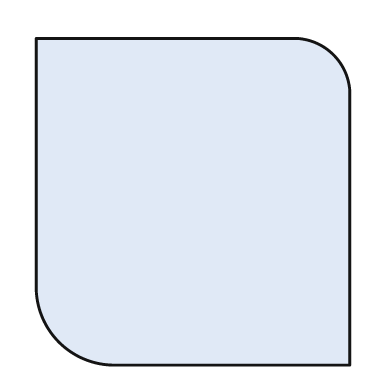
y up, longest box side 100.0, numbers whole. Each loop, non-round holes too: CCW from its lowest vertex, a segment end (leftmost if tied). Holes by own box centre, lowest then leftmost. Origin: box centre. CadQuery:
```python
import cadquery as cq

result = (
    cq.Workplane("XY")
    .moveTo(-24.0, -50.0)
    .lineTo(48.0, -50.0)
    .lineTo(48.0, 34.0)
    .threePointArc((43.0, 45.0), (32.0, 50.0))
    .lineTo(-48.0, 50.0)
    .lineTo(-48.0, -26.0)
    .threePointArc((-41.0, -43.0), (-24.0, -50.0))
    .close()
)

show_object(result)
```